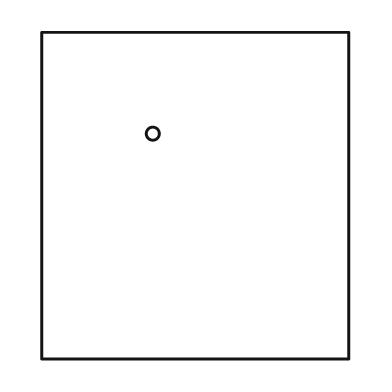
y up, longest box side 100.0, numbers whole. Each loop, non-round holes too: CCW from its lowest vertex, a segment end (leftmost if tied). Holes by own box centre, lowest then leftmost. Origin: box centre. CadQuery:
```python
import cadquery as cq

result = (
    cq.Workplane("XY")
    .moveTo(-47.0, -50.0)
    .lineTo(47.0, -50.0)
    .lineTo(47.0, 50.0)
    .lineTo(-47.0, 50.0)
    .close()
    .moveTo(-13.0, 19.0)
    .circle(2.0)
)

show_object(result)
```